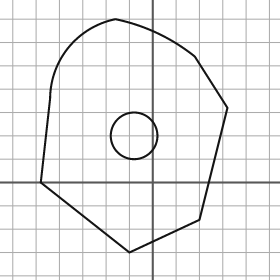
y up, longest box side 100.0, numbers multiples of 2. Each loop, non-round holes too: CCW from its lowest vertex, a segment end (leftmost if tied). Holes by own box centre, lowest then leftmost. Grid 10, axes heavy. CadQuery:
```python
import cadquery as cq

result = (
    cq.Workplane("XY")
    .moveTo(-10.0, -30.0)
    .lineTo(20.0, -16.0)
    .lineTo(32.0, 32.0)
    .lineTo(18.0, 54.0)
    .threePointArc((2.0, 64.0), (-16.0, 70.0))
    .threePointArc((-36.0, 58.0), (-44.0, 36.0))
    .lineTo(-48.0, 0.0)
    .close()
    .moveTo(-8.0, 20.0)
    .circle(10.0)
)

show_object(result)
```